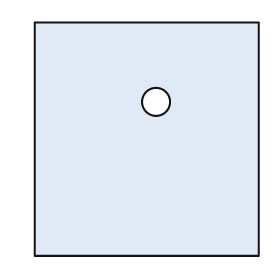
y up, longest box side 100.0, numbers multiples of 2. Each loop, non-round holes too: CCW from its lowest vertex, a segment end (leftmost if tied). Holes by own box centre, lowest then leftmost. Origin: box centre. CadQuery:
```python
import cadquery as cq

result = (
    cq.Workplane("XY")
    .moveTo(-48.0, -50.0)
    .lineTo(48.0, -50.0)
    .lineTo(48.0, 50.0)
    .lineTo(-48.0, 50.0)
    .close()
    .moveTo(4.0, 16.0)
    .circle(6.0)
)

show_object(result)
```